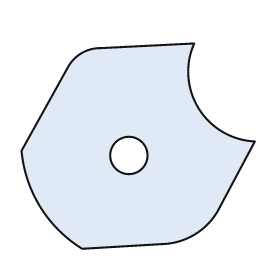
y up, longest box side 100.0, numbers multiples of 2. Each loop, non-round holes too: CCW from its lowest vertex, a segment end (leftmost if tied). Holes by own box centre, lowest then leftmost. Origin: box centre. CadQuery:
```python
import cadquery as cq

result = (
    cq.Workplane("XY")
    .moveTo(-24.0, -44.0)
    .lineTo(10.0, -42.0)
    .threePointArc((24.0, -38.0), (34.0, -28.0))
    .lineTo(50.0, 2.0)
    .threePointArc((26.0, 16.0), (24.0, 44.0))
    .lineTo(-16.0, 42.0)
    .threePointArc((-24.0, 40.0), (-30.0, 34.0))
    .lineTo(-50.0, -2.0)
    .threePointArc((-42.0, -26.0), (-24.0, -44.0))
    .close()
    .moveTo(-4.0, -4.0)
    .circle(8.0)
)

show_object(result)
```